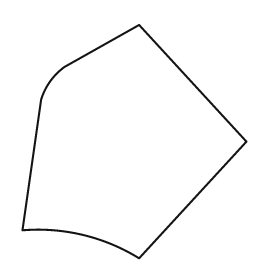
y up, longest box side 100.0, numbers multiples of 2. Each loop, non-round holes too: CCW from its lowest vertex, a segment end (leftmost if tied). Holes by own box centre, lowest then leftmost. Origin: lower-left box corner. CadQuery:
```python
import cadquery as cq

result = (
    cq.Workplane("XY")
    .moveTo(50.0, 0.0)
    .lineTo(96.0, 50.0)
    .lineTo(50.0, 100.0)
    .lineTo(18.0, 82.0)
    .threePointArc((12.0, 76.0), (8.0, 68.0))
    .lineTo(0.0, 12.0)
    .threePointArc((26.0, 10.0), (50.0, 0.0))
    .close()
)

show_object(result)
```